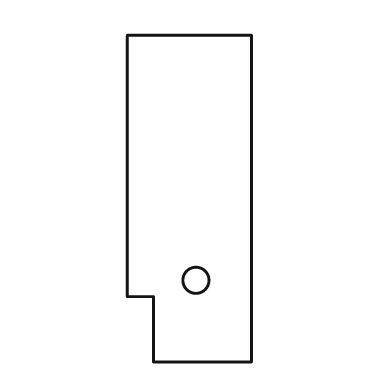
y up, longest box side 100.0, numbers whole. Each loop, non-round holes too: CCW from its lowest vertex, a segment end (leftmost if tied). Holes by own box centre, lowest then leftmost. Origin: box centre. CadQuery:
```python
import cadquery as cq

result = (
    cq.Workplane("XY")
    .moveTo(-11.0, -50.0)
    .lineTo(19.0, -50.0)
    .lineTo(19.0, 50.0)
    .lineTo(-19.0, 50.0)
    .lineTo(-19.0, -30.0)
    .lineTo(-11.0, -30.0)
    .close()
    .moveTo(2.0, -25.0)
    .circle(4.0)
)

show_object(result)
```